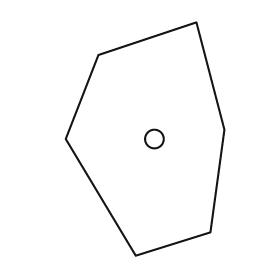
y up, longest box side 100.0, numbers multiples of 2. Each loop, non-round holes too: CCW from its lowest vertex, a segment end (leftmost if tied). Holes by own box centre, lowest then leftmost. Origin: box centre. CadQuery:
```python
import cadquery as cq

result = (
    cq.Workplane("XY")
    .moveTo(-4.0, -50.0)
    .lineTo(28.0, -40.0)
    .lineTo(34.0, 4.0)
    .lineTo(22.0, 50.0)
    .lineTo(-20.0, 36.0)
    .lineTo(-34.0, 0.0)
    .close()
    .moveTo(4.0, 0.0)
    .circle(4.0)
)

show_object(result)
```